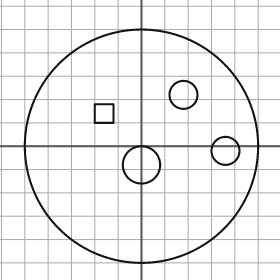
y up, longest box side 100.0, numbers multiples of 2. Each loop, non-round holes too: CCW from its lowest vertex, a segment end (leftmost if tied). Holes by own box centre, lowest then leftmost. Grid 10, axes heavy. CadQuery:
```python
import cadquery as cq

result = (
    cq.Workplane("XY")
    .moveTo(0.0, 0.0)
    .circle(50.0)
    .moveTo(0.0, -8.0)
    .circle(8.0)
    .moveTo(36.0, -2.0)
    .circle(6.0)
    .moveTo(-20.0, 10.0)
    .lineTo(-12.0, 10.0)
    .lineTo(-12.0, 18.0)
    .lineTo(-20.0, 18.0)
    .close()
    .moveTo(18.0, 22.0)
    .circle(6.0)
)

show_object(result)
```